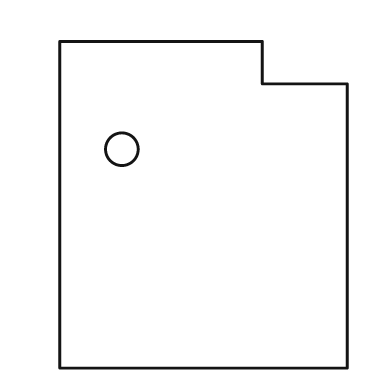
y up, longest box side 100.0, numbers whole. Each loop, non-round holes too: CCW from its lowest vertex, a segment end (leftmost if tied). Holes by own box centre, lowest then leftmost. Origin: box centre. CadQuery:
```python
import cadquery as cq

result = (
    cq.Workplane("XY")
    .moveTo(-44.0, -50.0)
    .lineTo(44.0, -50.0)
    .lineTo(44.0, 37.0)
    .lineTo(18.0, 37.0)
    .lineTo(18.0, 50.0)
    .lineTo(-44.0, 50.0)
    .close()
    .moveTo(-25.0, 17.0)
    .circle(5.0)
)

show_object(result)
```